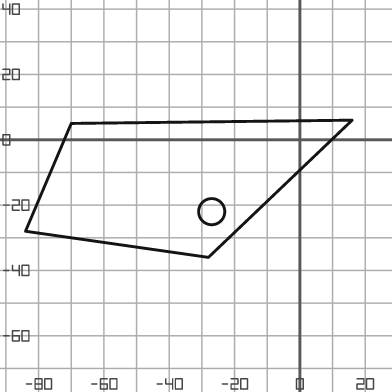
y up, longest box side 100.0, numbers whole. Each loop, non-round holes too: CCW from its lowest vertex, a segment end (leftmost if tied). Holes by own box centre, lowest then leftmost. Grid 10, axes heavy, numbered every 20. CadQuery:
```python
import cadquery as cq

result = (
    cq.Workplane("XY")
    .moveTo(-28.0, -36.0)
    .lineTo(16.0, 6.0)
    .lineTo(-70.0, 5.0)
    .lineTo(-84.0, -28.0)
    .close()
    .moveTo(-27.0, -22.0)
    .circle(4.0)
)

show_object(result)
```